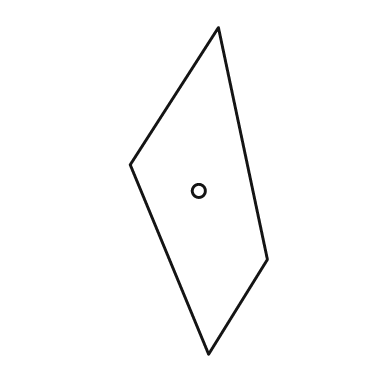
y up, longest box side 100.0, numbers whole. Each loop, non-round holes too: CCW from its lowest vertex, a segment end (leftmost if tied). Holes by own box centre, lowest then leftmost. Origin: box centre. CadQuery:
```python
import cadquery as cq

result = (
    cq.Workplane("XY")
    .moveTo(3.0, -50.0)
    .lineTo(21.0, -21.0)
    .lineTo(6.0, 50.0)
    .lineTo(-21.0, 8.0)
    .close()
    .moveTo(0.0, 0.0)
    .circle(2.0)
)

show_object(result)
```